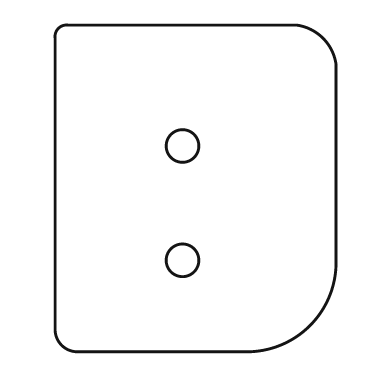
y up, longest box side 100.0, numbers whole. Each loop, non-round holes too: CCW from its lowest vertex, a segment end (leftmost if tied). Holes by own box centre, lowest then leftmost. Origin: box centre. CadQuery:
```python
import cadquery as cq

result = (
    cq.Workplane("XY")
    .moveTo(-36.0, -50.0)
    .lineTo(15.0, -50.0)
    .threePointArc((35.0, -42.0), (43.0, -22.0))
    .lineTo(43.0, 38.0)
    .threePointArc((39.0, 46.0), (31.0, 50.0))
    .lineTo(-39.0, 50.0)
    .threePointArc((-42.0, 49.0), (-43.0, 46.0))
    .lineTo(-43.0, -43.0)
    .threePointArc((-41.0, -48.0), (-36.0, -50.0))
    .close()
    .moveTo(-4.0, -22.0)
    .circle(5.0)
    .moveTo(-4.0, 13.0)
    .circle(5.0)
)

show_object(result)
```